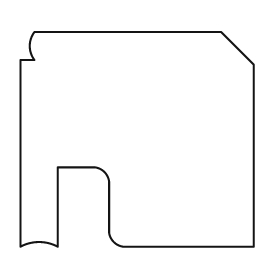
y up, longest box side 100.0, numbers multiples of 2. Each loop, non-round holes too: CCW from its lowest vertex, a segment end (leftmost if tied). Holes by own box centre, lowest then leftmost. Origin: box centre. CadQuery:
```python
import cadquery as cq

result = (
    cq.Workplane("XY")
    .moveTo(-50.0, -46.0)
    .threePointArc((-42.0, -44.0), (-34.0, -46.0))
    .lineTo(-34.0, -12.0)
    .lineTo(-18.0, -12.0)
    .threePointArc((-14.0, -14.0), (-12.0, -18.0))
    .lineTo(-12.0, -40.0)
    .threePointArc((-10.0, -44.0), (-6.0, -46.0))
    .lineTo(50.0, -46.0)
    .lineTo(50.0, 32.0)
    .lineTo(36.0, 46.0)
    .lineTo(-44.0, 46.0)
    .threePointArc((-46.0, 40.0), (-44.0, 34.0))
    .lineTo(-50.0, 34.0)
    .close()
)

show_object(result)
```